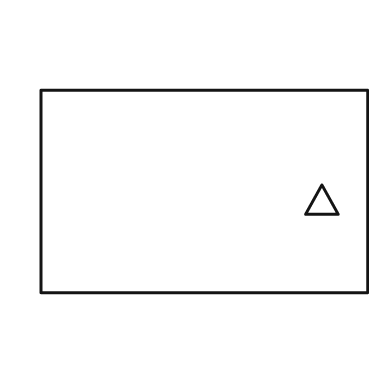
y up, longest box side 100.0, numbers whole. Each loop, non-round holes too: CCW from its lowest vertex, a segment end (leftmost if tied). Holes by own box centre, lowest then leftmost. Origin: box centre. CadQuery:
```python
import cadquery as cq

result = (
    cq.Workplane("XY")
    .moveTo(-50.0, -31.0)
    .lineTo(50.0, -31.0)
    .lineTo(50.0, 31.0)
    .lineTo(-50.0, 31.0)
    .close()
    .moveTo(31.0, -7.0)
    .lineTo(41.0, -7.0)
    .lineTo(36.0, 2.0)
    .close()
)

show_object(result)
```